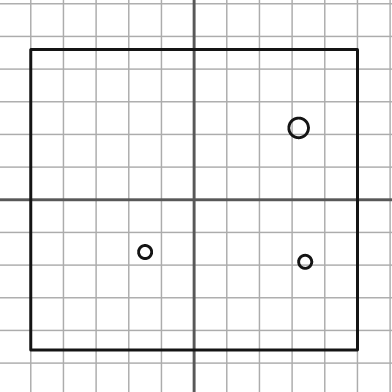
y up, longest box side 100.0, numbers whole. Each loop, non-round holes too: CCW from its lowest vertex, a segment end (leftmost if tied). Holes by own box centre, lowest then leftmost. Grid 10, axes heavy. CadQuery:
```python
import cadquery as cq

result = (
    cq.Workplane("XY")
    .moveTo(-50.0, -46.0)
    .lineTo(50.0, -46.0)
    .lineTo(50.0, 46.0)
    .lineTo(-50.0, 46.0)
    .close()
    .moveTo(34.0, -19.0)
    .circle(2.0)
    .moveTo(-15.0, -16.0)
    .circle(2.0)
    .moveTo(32.0, 22.0)
    .circle(3.0)
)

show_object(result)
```